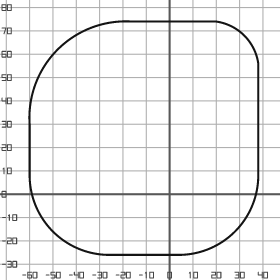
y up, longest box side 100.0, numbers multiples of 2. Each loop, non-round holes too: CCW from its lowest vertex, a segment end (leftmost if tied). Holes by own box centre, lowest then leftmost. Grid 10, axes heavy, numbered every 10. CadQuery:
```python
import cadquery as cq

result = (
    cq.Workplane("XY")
    .moveTo(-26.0, -26.0)
    .lineTo(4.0, -26.0)
    .threePointArc((28.0, -16.0), (38.0, 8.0))
    .lineTo(38.0, 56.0)
    .threePointArc((32.0, 68.0), (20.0, 74.0))
    .lineTo(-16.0, 74.0)
    .threePointArc((-48.0, 62.0), (-60.0, 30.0))
    .lineTo(-60.0, 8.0)
    .threePointArc((-50.0, -16.0), (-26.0, -26.0))
    .close()
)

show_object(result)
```